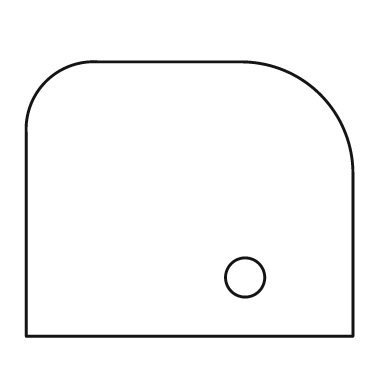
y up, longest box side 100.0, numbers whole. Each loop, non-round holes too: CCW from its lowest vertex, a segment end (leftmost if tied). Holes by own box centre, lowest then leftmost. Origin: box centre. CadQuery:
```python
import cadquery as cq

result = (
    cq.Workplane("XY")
    .moveTo(-50.0, -42.0)
    .lineTo(50.0, -42.0)
    .lineTo(50.0, 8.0)
    .threePointArc((40.0, 32.0), (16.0, 42.0))
    .lineTo(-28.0, 42.0)
    .threePointArc((-44.0, 36.0), (-50.0, 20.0))
    .close()
    .moveTo(17.0, -24.0)
    .circle(6.0)
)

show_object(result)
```